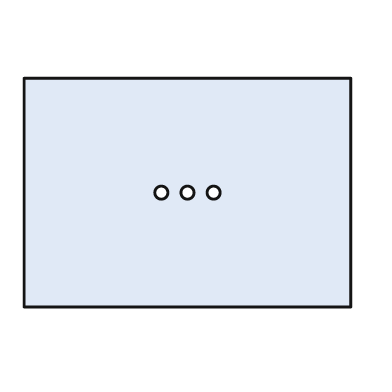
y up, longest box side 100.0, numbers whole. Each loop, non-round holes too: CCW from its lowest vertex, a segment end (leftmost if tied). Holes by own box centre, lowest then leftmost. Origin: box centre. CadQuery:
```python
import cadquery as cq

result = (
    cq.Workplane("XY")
    .moveTo(-50.0, -35.0)
    .lineTo(50.0, -35.0)
    .lineTo(50.0, 35.0)
    .lineTo(-50.0, 35.0)
    .close()
    .moveTo(-8.0, 0.0)
    .circle(2.0)
    .moveTo(0.0, 0.0)
    .circle(2.0)
    .moveTo(8.0, 0.0)
    .circle(2.0)
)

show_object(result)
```